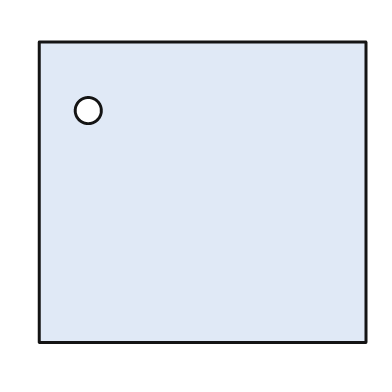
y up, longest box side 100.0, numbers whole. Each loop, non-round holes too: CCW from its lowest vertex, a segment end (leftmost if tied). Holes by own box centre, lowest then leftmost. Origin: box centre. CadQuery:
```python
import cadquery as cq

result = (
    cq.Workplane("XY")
    .moveTo(-50.0, -46.0)
    .lineTo(50.0, -46.0)
    .lineTo(50.0, 46.0)
    .lineTo(-50.0, 46.0)
    .close()
    .moveTo(-35.0, 25.0)
    .circle(4.0)
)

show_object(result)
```